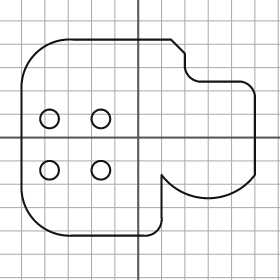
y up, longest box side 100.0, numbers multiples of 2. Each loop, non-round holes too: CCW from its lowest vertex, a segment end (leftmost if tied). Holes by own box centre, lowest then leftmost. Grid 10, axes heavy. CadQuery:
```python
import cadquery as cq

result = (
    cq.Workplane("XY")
    .moveTo(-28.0, -42.0)
    .lineTo(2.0, -42.0)
    .threePointArc((8.0, -40.0), (10.0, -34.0))
    .lineTo(10.0, -16.0)
    .threePointArc((30.0, -26.0), (50.0, -16.0))
    .lineTo(50.0, 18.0)
    .threePointArc((48.0, 22.0), (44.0, 24.0))
    .lineTo(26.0, 24.0)
    .threePointArc((22.0, 26.0), (20.0, 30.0))
    .lineTo(20.0, 36.0)
    .lineTo(14.0, 42.0)
    .lineTo(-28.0, 42.0)
    .threePointArc((-44.0, 36.0), (-50.0, 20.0))
    .lineTo(-50.0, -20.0)
    .threePointArc((-44.0, -36.0), (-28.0, -42.0))
    .close()
    .moveTo(-38.0, -14.0)
    .circle(4.0)
    .moveTo(-16.0, -14.0)
    .circle(4.0)
    .moveTo(-38.0, 8.0)
    .circle(4.0)
    .moveTo(-16.0, 8.0)
    .circle(4.0)
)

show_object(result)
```